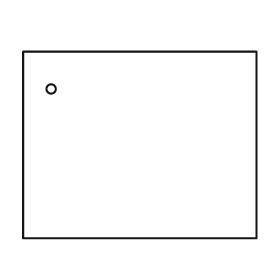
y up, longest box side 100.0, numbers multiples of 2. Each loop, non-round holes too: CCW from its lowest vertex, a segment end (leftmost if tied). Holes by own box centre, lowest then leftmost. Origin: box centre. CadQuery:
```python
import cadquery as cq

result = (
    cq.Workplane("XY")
    .moveTo(-50.0, -40.0)
    .lineTo(50.0, -40.0)
    .lineTo(50.0, 40.0)
    .lineTo(-50.0, 40.0)
    .close()
    .moveTo(-38.0, 24.0)
    .circle(2.0)
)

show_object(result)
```